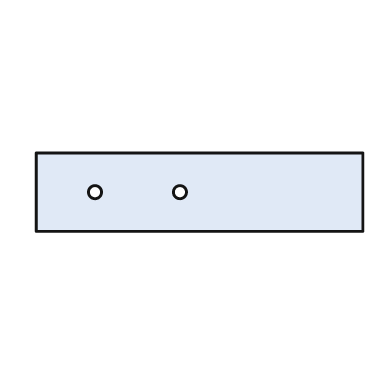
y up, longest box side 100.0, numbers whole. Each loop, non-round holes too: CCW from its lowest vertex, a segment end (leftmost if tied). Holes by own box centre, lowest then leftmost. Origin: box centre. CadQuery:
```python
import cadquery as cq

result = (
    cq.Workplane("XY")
    .moveTo(-50.0, -12.0)
    .lineTo(50.0, -12.0)
    .lineTo(50.0, 12.0)
    .lineTo(-50.0, 12.0)
    .close()
    .moveTo(-32.0, 0.0)
    .circle(2.0)
    .moveTo(-6.0, 0.0)
    .circle(2.0)
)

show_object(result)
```